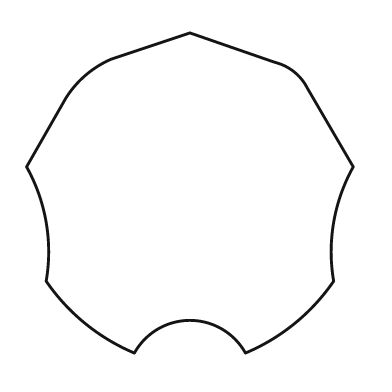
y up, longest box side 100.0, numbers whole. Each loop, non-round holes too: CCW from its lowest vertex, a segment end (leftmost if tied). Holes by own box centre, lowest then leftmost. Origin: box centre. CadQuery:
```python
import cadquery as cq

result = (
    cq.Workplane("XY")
    .moveTo(-17.0, -49.0)
    .threePointArc((0.0, -39.0), (17.0, -49.0))
    .threePointArc((32.0, -40.0), (44.0, -27.0))
    .threePointArc((44.0, -9.0), (50.0, 8.0))
    .lineTo(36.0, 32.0)
    .threePointArc((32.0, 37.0), (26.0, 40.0))
    .lineTo(0.0, 49.0)
    .lineTo(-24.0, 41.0)
    .threePointArc((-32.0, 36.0), (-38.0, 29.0))
    .lineTo(-50.0, 8.0)
    .threePointArc((-44.0, -9.0), (-44.0, -27.0))
    .threePointArc((-32.0, -40.0), (-17.0, -49.0))
    .close()
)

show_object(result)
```